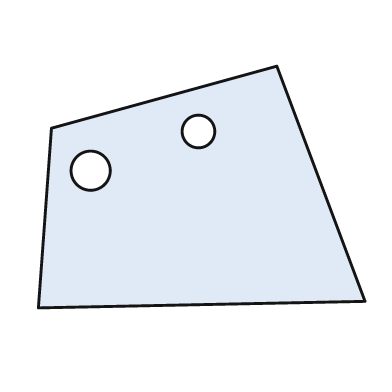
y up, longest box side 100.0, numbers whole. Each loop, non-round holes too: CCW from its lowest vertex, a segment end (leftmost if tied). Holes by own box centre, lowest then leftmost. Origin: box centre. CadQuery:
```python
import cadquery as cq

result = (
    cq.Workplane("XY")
    .moveTo(-50.0, -37.0)
    .lineTo(50.0, -35.0)
    .lineTo(23.0, 37.0)
    .lineTo(-46.0, 18.0)
    .close()
    .moveTo(-34.0, 5.0)
    .circle(6.0)
    .moveTo(-1.0, 17.0)
    .circle(5.0)
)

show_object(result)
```